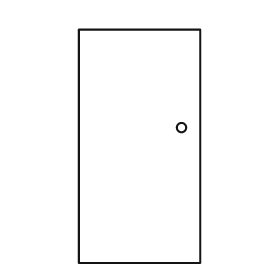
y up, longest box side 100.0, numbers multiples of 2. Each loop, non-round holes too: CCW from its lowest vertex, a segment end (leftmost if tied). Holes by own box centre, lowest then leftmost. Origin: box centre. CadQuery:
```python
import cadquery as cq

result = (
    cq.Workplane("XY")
    .moveTo(-26.0, -50.0)
    .lineTo(26.0, -50.0)
    .lineTo(26.0, 50.0)
    .lineTo(-26.0, 50.0)
    .close()
    .moveTo(18.0, 8.0)
    .circle(2.0)
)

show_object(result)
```